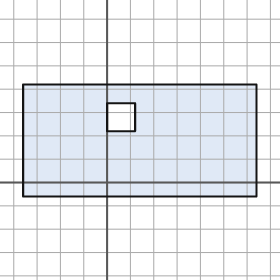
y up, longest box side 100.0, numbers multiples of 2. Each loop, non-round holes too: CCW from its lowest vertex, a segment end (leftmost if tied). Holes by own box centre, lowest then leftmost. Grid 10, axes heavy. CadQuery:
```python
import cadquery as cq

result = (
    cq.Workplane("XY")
    .moveTo(-36.0, -6.0)
    .lineTo(64.0, -6.0)
    .lineTo(64.0, 42.0)
    .lineTo(-36.0, 42.0)
    .close()
    .moveTo(0.0, 22.0)
    .lineTo(12.0, 22.0)
    .lineTo(12.0, 34.0)
    .lineTo(0.0, 34.0)
    .close()
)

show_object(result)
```